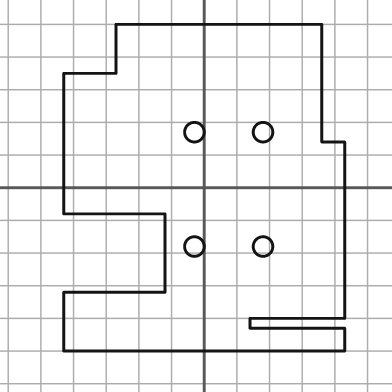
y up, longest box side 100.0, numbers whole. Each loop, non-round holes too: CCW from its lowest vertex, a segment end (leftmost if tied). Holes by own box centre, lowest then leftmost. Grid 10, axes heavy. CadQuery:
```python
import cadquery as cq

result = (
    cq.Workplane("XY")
    .moveTo(-43.0, -50.0)
    .lineTo(43.0, -50.0)
    .lineTo(43.0, -43.0)
    .lineTo(14.0, -43.0)
    .lineTo(14.0, -40.0)
    .lineTo(43.0, -40.0)
    .lineTo(43.0, 14.0)
    .lineTo(36.0, 14.0)
    .lineTo(36.0, 50.0)
    .lineTo(-27.0, 50.0)
    .lineTo(-27.0, 35.0)
    .lineTo(-43.0, 35.0)
    .lineTo(-43.0, -8.0)
    .lineTo(-12.0, -8.0)
    .lineTo(-12.0, -32.0)
    .lineTo(-43.0, -32.0)
    .close()
    .moveTo(-3.0, -18.0)
    .circle(3.0)
    .moveTo(18.0, -18.0)
    .circle(3.0)
    .moveTo(-3.0, 17.0)
    .circle(3.0)
    .moveTo(18.0, 17.0)
    .circle(3.0)
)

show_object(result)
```